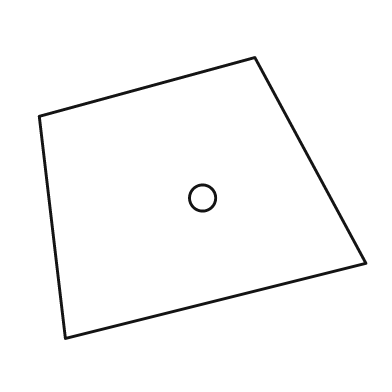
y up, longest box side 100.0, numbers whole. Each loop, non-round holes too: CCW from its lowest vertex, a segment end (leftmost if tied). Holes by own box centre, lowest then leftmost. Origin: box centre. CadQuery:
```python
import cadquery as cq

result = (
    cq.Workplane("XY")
    .moveTo(-42.0, -43.0)
    .lineTo(50.0, -20.0)
    .lineTo(16.0, 43.0)
    .lineTo(-50.0, 25.0)
    .close()
    .moveTo(0.0, 0.0)
    .circle(4.0)
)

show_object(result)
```